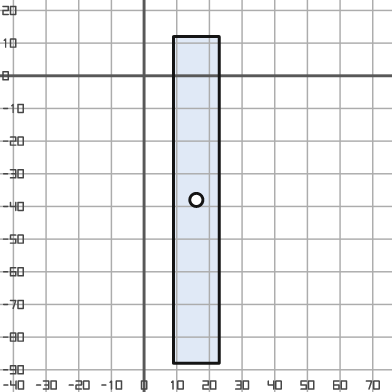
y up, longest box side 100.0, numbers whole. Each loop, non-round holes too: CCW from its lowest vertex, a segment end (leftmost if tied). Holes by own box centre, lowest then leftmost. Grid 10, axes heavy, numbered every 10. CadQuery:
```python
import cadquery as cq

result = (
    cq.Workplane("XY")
    .moveTo(9.0, -88.0)
    .lineTo(23.0, -88.0)
    .lineTo(23.0, 12.0)
    .lineTo(9.0, 12.0)
    .close()
    .moveTo(16.0, -38.0)
    .circle(2.0)
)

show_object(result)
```